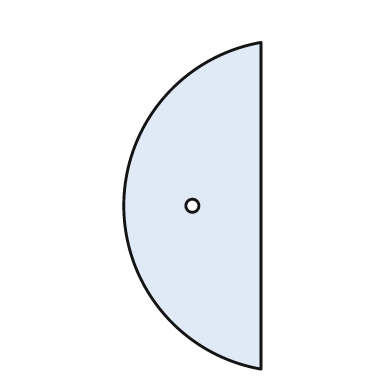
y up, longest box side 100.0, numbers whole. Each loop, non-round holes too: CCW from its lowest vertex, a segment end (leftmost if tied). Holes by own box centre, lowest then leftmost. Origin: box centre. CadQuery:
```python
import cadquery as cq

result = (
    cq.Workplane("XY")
    .moveTo(21.0, -50.0)
    .lineTo(21.0, 50.0)
    .threePointArc((-21.0, 0.0), (21.0, -50.0))
    .close()
    .moveTo(0.0, 0.0)
    .circle(2.0)
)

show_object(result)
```